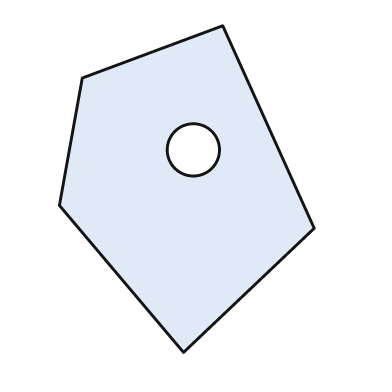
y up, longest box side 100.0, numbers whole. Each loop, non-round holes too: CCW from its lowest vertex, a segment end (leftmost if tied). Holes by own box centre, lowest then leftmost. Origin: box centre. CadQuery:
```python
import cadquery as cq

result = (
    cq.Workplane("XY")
    .moveTo(-1.0, -50.0)
    .lineTo(39.0, -12.0)
    .lineTo(11.0, 50.0)
    .lineTo(-32.0, 34.0)
    .lineTo(-39.0, -5.0)
    .close()
    .moveTo(2.0, 12.0)
    .circle(8.0)
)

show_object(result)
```